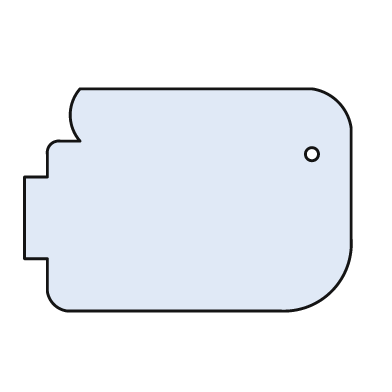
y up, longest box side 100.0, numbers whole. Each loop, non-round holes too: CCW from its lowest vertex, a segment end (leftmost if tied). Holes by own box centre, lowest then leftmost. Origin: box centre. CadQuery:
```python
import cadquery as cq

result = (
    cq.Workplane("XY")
    .moveTo(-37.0, -34.0)
    .lineTo(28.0, -34.0)
    .threePointArc((44.0, -28.0), (50.0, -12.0))
    .lineTo(50.0, 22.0)
    .threePointArc((46.0, 30.0), (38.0, 34.0))
    .lineTo(-33.0, 34.0)
    .threePointArc((-36.0, 26.0), (-33.0, 18.0))
    .lineTo(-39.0, 18.0)
    .threePointArc((-42.0, 17.0), (-43.0, 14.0))
    .lineTo(-43.0, 7.0)
    .lineTo(-50.0, 7.0)
    .lineTo(-50.0, -18.0)
    .lineTo(-43.0, -18.0)
    .lineTo(-43.0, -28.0)
    .threePointArc((-41.0, -32.0), (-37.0, -34.0))
    .close()
    .moveTo(38.0, 14.0)
    .circle(2.0)
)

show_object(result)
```